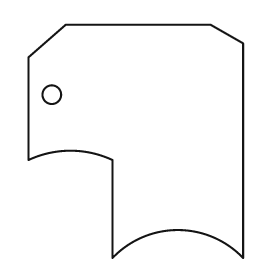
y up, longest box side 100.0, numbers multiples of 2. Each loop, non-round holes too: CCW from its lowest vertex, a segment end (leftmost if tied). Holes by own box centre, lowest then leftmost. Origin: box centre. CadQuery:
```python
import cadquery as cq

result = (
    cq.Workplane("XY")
    .moveTo(-10.0, -50.0)
    .threePointArc((18.0, -38.0), (46.0, -50.0))
    .lineTo(46.0, 42.0)
    .lineTo(32.0, 50.0)
    .lineTo(-30.0, 50.0)
    .lineTo(-46.0, 36.0)
    .lineTo(-46.0, -8.0)
    .threePointArc((-28.0, -4.0), (-10.0, -8.0))
    .close()
    .moveTo(-36.0, 20.0)
    .circle(4.0)
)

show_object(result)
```